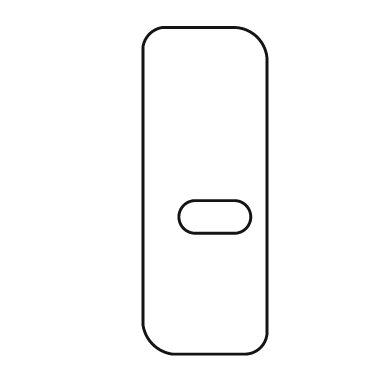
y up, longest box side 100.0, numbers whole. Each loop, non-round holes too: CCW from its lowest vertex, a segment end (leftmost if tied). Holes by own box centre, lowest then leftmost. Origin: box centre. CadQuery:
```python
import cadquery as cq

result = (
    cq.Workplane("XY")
    .moveTo(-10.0, -50.0)
    .lineTo(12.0, -50.0)
    .threePointArc((17.0, -48.0), (19.0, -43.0))
    .lineTo(19.0, 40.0)
    .threePointArc((16.0, 47.0), (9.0, 50.0))
    .lineTo(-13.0, 50.0)
    .threePointArc((-17.0, 48.0), (-19.0, 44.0))
    .lineTo(-19.0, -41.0)
    .threePointArc((-16.0, -47.0), (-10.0, -50.0))
    .close()
    .moveTo(-3.0, -13.0)
    .lineTo(9.0, -13.0)
    .threePointArc((14.0, -8.0), (9.0, -3.0))
    .lineTo(-3.0, -3.0)
    .threePointArc((-8.0, -8.0), (-3.0, -13.0))
    .close()
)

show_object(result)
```